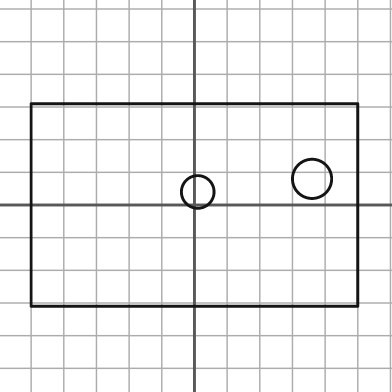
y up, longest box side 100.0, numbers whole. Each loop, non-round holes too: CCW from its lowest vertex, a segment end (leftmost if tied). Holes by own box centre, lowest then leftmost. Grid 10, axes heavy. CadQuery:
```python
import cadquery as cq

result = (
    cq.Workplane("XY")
    .moveTo(-50.0, -31.0)
    .lineTo(50.0, -31.0)
    .lineTo(50.0, 31.0)
    .lineTo(-50.0, 31.0)
    .close()
    .moveTo(1.0, 4.0)
    .circle(5.0)
    .moveTo(36.0, 8.0)
    .circle(6.0)
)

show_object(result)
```